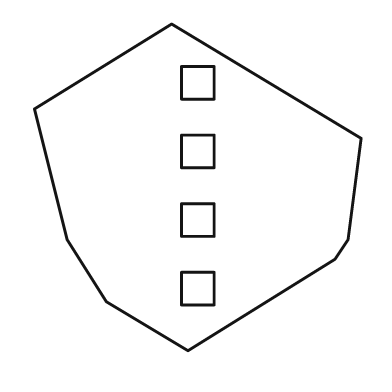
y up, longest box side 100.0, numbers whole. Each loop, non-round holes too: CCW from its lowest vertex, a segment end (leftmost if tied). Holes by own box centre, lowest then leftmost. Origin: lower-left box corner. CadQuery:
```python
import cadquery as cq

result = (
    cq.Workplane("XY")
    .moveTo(47.0, 0.0)
    .lineTo(92.0, 28.0)
    .lineTo(96.0, 34.0)
    .lineTo(100.0, 65.0)
    .lineTo(42.0, 100.0)
    .lineTo(0.0, 74.0)
    .lineTo(10.0, 34.0)
    .lineTo(22.0, 15.0)
    .close()
    .moveTo(45.0, 14.0)
    .lineTo(55.0, 14.0)
    .lineTo(55.0, 24.0)
    .lineTo(45.0, 24.0)
    .close()
    .moveTo(45.0, 35.0)
    .lineTo(55.0, 35.0)
    .lineTo(55.0, 45.0)
    .lineTo(45.0, 45.0)
    .close()
    .moveTo(45.0, 56.0)
    .lineTo(55.0, 56.0)
    .lineTo(55.0, 66.0)
    .lineTo(45.0, 66.0)
    .close()
    .moveTo(45.0, 77.0)
    .lineTo(55.0, 77.0)
    .lineTo(55.0, 87.0)
    .lineTo(45.0, 87.0)
    .close()
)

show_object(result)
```